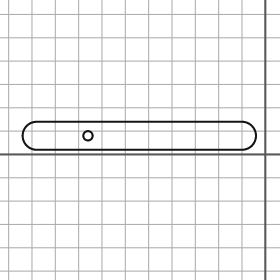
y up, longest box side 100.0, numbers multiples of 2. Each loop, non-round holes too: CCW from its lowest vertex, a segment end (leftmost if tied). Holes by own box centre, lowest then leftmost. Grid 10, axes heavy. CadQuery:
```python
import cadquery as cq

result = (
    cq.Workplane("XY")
    .moveTo(-98.0, 2.0)
    .lineTo(-10.0, 2.0)
    .threePointArc((-4.0, 8.0), (-10.0, 14.0))
    .lineTo(-98.0, 14.0)
    .threePointArc((-104.0, 8.0), (-98.0, 2.0))
    .close()
    .moveTo(-76.0, 8.0)
    .circle(2.0)
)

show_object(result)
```